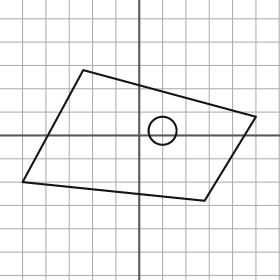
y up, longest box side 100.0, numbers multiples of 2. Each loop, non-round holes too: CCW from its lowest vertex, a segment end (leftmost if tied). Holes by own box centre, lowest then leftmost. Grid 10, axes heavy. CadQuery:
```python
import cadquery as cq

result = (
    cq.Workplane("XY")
    .moveTo(28.0, -28.0)
    .lineTo(50.0, 8.0)
    .lineTo(-24.0, 28.0)
    .lineTo(-50.0, -20.0)
    .close()
    .moveTo(10.0, 2.0)
    .circle(6.0)
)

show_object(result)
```